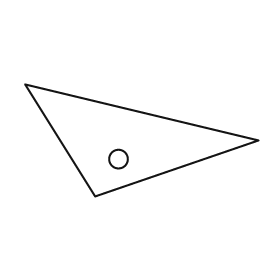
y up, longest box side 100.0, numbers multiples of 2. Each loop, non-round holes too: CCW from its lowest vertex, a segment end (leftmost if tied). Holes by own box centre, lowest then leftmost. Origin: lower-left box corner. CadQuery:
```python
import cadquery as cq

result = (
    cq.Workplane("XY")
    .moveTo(30.0, 0.0)
    .lineTo(100.0, 24.0)
    .lineTo(0.0, 48.0)
    .close()
    .moveTo(40.0, 16.0)
    .circle(4.0)
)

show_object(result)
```